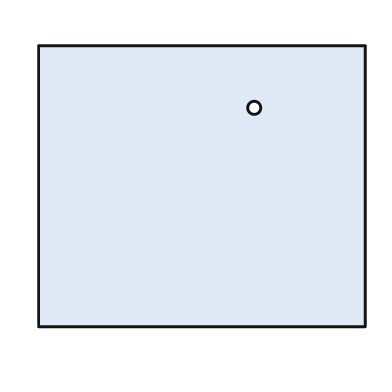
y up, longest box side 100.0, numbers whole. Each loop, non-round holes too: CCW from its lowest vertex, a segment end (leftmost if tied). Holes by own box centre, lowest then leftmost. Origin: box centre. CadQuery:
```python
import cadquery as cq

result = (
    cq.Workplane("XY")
    .moveTo(-50.0, -43.0)
    .lineTo(50.0, -43.0)
    .lineTo(50.0, 43.0)
    .lineTo(-50.0, 43.0)
    .close()
    .moveTo(16.0, 24.0)
    .circle(2.0)
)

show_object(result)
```